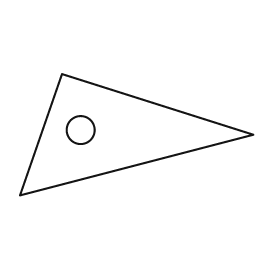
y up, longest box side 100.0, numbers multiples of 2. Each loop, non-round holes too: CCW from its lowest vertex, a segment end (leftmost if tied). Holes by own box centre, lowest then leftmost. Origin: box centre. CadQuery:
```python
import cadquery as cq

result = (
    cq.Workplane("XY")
    .moveTo(-50.0, -26.0)
    .lineTo(50.0, 0.0)
    .lineTo(-32.0, 26.0)
    .close()
    .moveTo(-24.0, 2.0)
    .circle(6.0)
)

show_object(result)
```